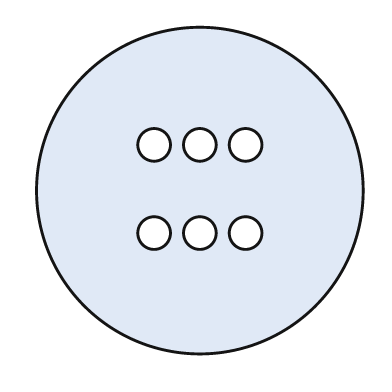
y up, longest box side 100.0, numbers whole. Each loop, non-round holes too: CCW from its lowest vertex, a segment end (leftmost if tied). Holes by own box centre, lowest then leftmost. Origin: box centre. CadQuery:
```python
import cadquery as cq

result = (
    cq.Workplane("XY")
    .moveTo(0.0, 0.0)
    .circle(50.0)
    .moveTo(-14.0, -13.0)
    .circle(5.0)
    .moveTo(0.0, -13.0)
    .circle(5.0)
    .moveTo(14.0, -13.0)
    .circle(5.0)
    .moveTo(-14.0, 14.0)
    .circle(5.0)
    .moveTo(0.0, 14.0)
    .circle(5.0)
    .moveTo(14.0, 14.0)
    .circle(5.0)
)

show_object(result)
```